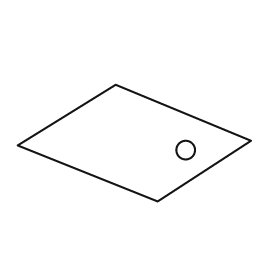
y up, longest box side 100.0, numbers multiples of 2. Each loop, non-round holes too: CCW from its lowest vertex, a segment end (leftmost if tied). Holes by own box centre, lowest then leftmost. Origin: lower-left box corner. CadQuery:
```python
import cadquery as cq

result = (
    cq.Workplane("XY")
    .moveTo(60.0, 0.0)
    .lineTo(100.0, 26.0)
    .lineTo(42.0, 50.0)
    .lineTo(0.0, 24.0)
    .close()
    .moveTo(72.0, 22.0)
    .circle(4.0)
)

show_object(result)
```